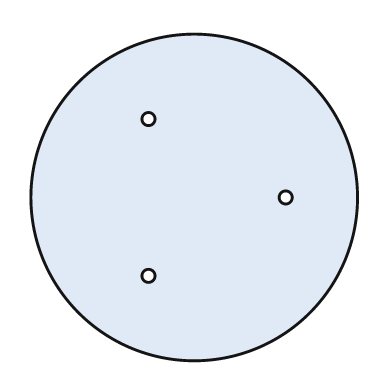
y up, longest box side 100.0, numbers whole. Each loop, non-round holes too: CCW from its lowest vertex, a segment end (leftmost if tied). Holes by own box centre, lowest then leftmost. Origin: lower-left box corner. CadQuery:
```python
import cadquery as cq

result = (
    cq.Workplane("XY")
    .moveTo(50.0, 50.0)
    .circle(50.0)
    .moveTo(36.0, 26.0)
    .circle(2.0)
    .moveTo(78.0, 50.0)
    .circle(2.0)
    .moveTo(36.0, 74.0)
    .circle(2.0)
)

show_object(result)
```